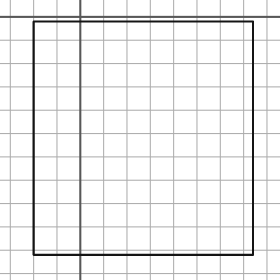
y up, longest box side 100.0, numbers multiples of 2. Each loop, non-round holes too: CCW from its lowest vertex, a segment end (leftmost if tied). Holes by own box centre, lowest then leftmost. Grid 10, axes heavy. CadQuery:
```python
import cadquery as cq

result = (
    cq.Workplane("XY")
    .moveTo(-20.0, -102.0)
    .lineTo(74.0, -102.0)
    .lineTo(74.0, -2.0)
    .lineTo(-20.0, -2.0)
    .close()
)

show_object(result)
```